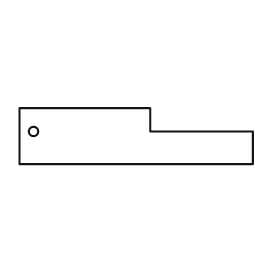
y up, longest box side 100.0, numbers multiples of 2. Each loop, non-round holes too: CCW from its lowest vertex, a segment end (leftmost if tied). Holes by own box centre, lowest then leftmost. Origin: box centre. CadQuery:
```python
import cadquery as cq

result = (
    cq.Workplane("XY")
    .moveTo(-50.0, -12.0)
    .lineTo(50.0, -12.0)
    .lineTo(50.0, 2.0)
    .lineTo(6.0, 2.0)
    .lineTo(6.0, 12.0)
    .lineTo(-50.0, 12.0)
    .close()
    .moveTo(-44.0, 2.0)
    .circle(2.0)
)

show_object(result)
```